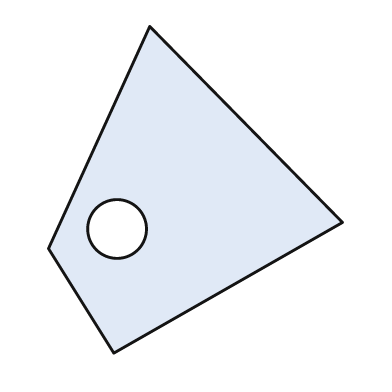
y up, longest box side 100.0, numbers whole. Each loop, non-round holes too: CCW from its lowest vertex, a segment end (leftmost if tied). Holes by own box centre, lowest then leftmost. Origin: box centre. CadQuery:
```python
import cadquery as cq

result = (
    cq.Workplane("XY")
    .moveTo(-25.0, -50.0)
    .lineTo(45.0, -10.0)
    .lineTo(-14.0, 50.0)
    .lineTo(-45.0, -18.0)
    .close()
    .moveTo(-24.0, -12.0)
    .circle(9.0)
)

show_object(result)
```